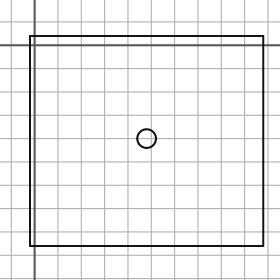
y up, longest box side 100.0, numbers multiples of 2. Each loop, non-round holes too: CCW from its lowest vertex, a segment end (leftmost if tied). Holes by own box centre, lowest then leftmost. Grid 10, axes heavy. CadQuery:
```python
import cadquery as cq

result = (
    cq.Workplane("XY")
    .moveTo(-2.0, -86.0)
    .lineTo(98.0, -86.0)
    .lineTo(98.0, 4.0)
    .lineTo(-2.0, 4.0)
    .close()
    .moveTo(48.0, -40.0)
    .circle(4.0)
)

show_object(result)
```